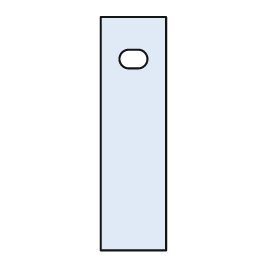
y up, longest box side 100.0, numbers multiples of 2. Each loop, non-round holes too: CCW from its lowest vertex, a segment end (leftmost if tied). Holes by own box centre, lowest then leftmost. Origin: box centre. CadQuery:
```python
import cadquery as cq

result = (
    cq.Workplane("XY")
    .moveTo(-14.0, -50.0)
    .lineTo(14.0, -50.0)
    .lineTo(14.0, 50.0)
    .lineTo(-14.0, 50.0)
    .close()
    .moveTo(-2.0, 28.0)
    .lineTo(2.0, 28.0)
    .threePointArc((6.0, 32.0), (2.0, 36.0))
    .lineTo(-2.0, 36.0)
    .threePointArc((-6.0, 32.0), (-2.0, 28.0))
    .close()
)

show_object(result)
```